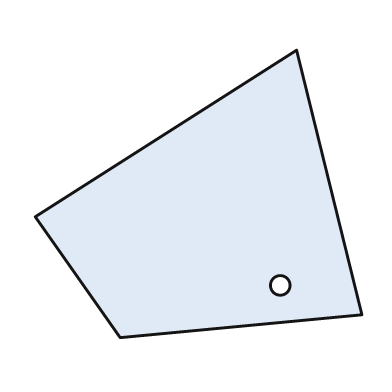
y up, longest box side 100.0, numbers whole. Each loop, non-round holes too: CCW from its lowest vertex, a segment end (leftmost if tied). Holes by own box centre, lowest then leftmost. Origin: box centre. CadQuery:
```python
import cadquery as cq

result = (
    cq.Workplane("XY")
    .moveTo(-24.0, -44.0)
    .lineTo(50.0, -37.0)
    .lineTo(30.0, 44.0)
    .lineTo(-50.0, -7.0)
    .close()
    .moveTo(25.0, -28.0)
    .circle(3.0)
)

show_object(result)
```